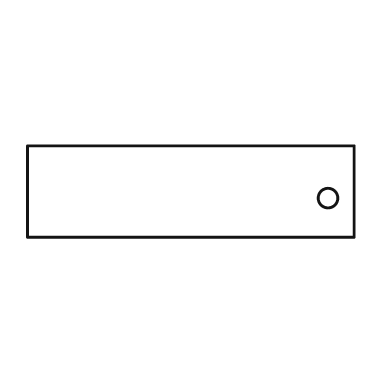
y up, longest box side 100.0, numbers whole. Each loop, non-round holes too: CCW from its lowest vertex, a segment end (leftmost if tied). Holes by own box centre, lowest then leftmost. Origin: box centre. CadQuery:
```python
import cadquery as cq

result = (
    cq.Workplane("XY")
    .moveTo(-50.0, -14.0)
    .lineTo(50.0, -14.0)
    .lineTo(50.0, 14.0)
    .lineTo(-50.0, 14.0)
    .close()
    .moveTo(42.0, -2.0)
    .circle(3.0)
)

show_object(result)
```